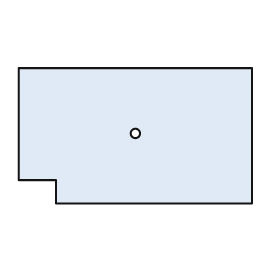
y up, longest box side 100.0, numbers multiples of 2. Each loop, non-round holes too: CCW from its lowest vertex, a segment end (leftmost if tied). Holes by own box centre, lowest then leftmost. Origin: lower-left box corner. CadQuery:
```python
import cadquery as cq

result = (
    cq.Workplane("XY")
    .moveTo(16.0, 0.0)
    .lineTo(100.0, 0.0)
    .lineTo(100.0, 58.0)
    .lineTo(0.0, 58.0)
    .lineTo(0.0, 10.0)
    .lineTo(16.0, 10.0)
    .close()
    .moveTo(50.0, 30.0)
    .circle(2.0)
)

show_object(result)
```